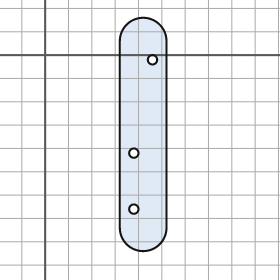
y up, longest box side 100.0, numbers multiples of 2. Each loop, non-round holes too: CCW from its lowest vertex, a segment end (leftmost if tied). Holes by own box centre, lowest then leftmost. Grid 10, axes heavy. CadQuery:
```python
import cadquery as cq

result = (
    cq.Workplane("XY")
    .moveTo(32.0, -74.0)
    .threePointArc((42.0, -84.0), (52.0, -74.0))
    .lineTo(52.0, 6.0)
    .threePointArc((42.0, 16.0), (32.0, 6.0))
    .close()
    .moveTo(38.0, -66.0)
    .circle(2.0)
    .moveTo(38.0, -42.0)
    .circle(2.0)
    .moveTo(46.0, -2.0)
    .circle(2.0)
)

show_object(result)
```